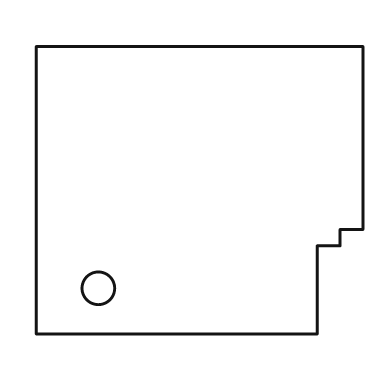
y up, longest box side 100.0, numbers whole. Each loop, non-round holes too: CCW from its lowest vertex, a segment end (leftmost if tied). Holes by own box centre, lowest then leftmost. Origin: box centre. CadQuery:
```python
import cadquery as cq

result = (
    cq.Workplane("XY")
    .moveTo(-50.0, -44.0)
    .lineTo(36.0, -44.0)
    .lineTo(36.0, -17.0)
    .lineTo(43.0, -17.0)
    .lineTo(43.0, -12.0)
    .lineTo(50.0, -12.0)
    .lineTo(50.0, 44.0)
    .lineTo(-50.0, 44.0)
    .close()
    .moveTo(-31.0, -30.0)
    .circle(5.0)
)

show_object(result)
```